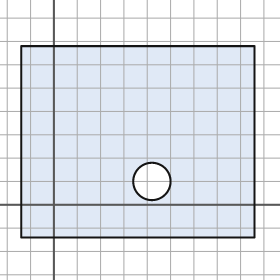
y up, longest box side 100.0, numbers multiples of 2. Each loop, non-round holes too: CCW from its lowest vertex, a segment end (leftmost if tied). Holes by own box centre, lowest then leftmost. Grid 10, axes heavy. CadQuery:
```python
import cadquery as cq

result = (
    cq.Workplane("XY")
    .moveTo(-14.0, -14.0)
    .lineTo(86.0, -14.0)
    .lineTo(86.0, 68.0)
    .lineTo(-14.0, 68.0)
    .close()
    .moveTo(42.0, 10.0)
    .circle(8.0)
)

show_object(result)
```